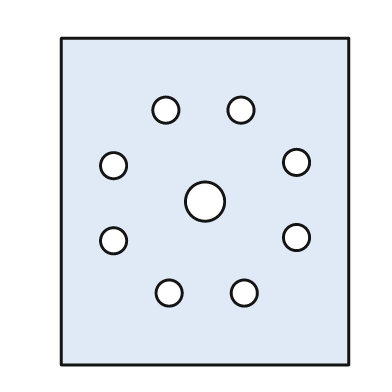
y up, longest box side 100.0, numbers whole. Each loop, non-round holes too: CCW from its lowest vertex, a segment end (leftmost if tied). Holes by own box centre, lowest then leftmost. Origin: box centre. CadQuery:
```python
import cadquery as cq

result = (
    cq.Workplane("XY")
    .moveTo(-44.0, -50.0)
    .lineTo(44.0, -50.0)
    .lineTo(44.0, 50.0)
    .lineTo(-44.0, 50.0)
    .close()
    .moveTo(-11.0, -28.0)
    .circle(4.0)
    .moveTo(12.0, -28.0)
    .circle(4.0)
    .moveTo(-28.0, -12.0)
    .circle(4.0)
    .moveTo(28.0, -11.0)
    .circle(4.0)
    .moveTo(0.0, 0.0)
    .circle(6.0)
    .moveTo(-28.0, 11.0)
    .circle(4.0)
    .moveTo(28.0, 12.0)
    .circle(4.0)
    .moveTo(-12.0, 28.0)
    .circle(4.0)
    .moveTo(11.0, 28.0)
    .circle(4.0)
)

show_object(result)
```